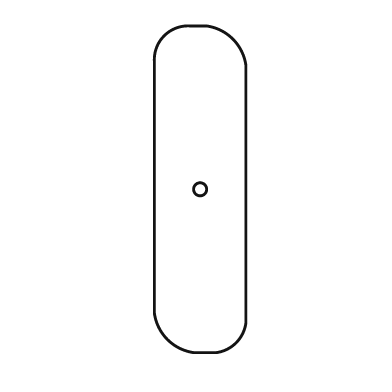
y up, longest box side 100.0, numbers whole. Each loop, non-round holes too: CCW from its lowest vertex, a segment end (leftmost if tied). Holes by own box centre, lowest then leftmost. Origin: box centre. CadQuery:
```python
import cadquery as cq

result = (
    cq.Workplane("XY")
    .moveTo(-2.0, -50.0)
    .lineTo(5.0, -50.0)
    .threePointArc((11.0, -47.0), (14.0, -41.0))
    .lineTo(14.0, 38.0)
    .threePointArc((10.0, 46.0), (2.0, 50.0))
    .lineTo(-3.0, 50.0)
    .threePointArc((-11.0, 47.0), (-14.0, 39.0))
    .lineTo(-14.0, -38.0)
    .threePointArc((-10.0, -46.0), (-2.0, -50.0))
    .close()
    .moveTo(0.0, 0.0)
    .circle(2.0)
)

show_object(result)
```